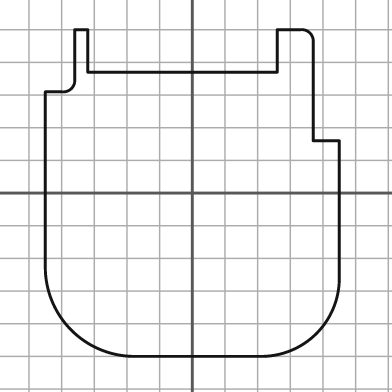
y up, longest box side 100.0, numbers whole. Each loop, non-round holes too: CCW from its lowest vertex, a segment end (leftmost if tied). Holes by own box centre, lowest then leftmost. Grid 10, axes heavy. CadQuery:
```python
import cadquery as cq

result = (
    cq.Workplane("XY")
    .moveTo(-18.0, -50.0)
    .lineTo(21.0, -50.0)
    .threePointArc((38.0, -43.0), (45.0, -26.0))
    .lineTo(45.0, 16.0)
    .lineTo(37.0, 16.0)
    .lineTo(37.0, 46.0)
    .threePointArc((36.0, 49.0), (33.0, 50.0))
    .lineTo(26.0, 50.0)
    .lineTo(26.0, 37.0)
    .lineTo(-32.0, 37.0)
    .lineTo(-32.0, 50.0)
    .lineTo(-36.0, 50.0)
    .lineTo(-36.0, 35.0)
    .threePointArc((-37.0, 32.0), (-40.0, 31.0))
    .lineTo(-45.0, 31.0)
    .lineTo(-45.0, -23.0)
    .threePointArc((-37.0, -42.0), (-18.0, -50.0))
    .close()
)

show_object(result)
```